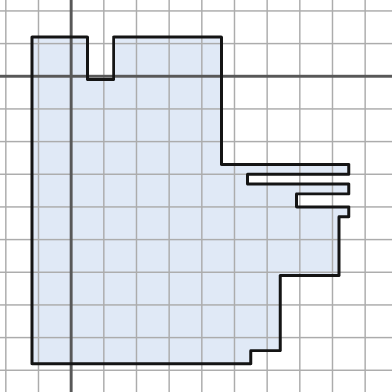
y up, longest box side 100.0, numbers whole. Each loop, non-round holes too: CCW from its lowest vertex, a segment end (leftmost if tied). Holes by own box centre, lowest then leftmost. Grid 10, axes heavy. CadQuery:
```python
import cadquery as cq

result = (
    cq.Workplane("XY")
    .moveTo(-12.0, -88.0)
    .lineTo(55.0, -88.0)
    .lineTo(55.0, -84.0)
    .lineTo(64.0, -84.0)
    .lineTo(64.0, -61.0)
    .lineTo(82.0, -61.0)
    .lineTo(82.0, -43.0)
    .lineTo(85.0, -43.0)
    .lineTo(85.0, -40.0)
    .lineTo(69.0, -40.0)
    .lineTo(69.0, -36.0)
    .lineTo(85.0, -36.0)
    .lineTo(85.0, -33.0)
    .lineTo(54.0, -33.0)
    .lineTo(54.0, -30.0)
    .lineTo(85.0, -30.0)
    .lineTo(85.0, -27.0)
    .lineTo(46.0, -27.0)
    .lineTo(46.0, 12.0)
    .lineTo(13.0, 12.0)
    .lineTo(13.0, -1.0)
    .lineTo(5.0, -1.0)
    .lineTo(5.0, 12.0)
    .lineTo(-12.0, 12.0)
    .close()
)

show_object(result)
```